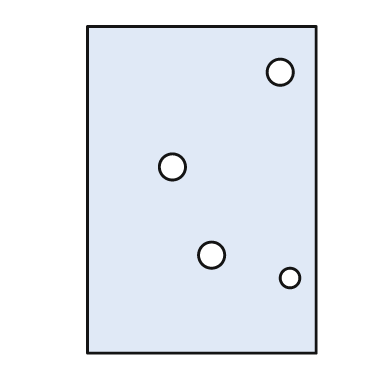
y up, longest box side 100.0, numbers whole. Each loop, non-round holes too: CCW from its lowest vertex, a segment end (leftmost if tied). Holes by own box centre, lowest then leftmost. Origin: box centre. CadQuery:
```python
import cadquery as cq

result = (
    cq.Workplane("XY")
    .moveTo(-35.0, -50.0)
    .lineTo(35.0, -50.0)
    .lineTo(35.0, 50.0)
    .lineTo(-35.0, 50.0)
    .close()
    .moveTo(27.0, -27.0)
    .circle(3.0)
    .moveTo(3.0, -20.0)
    .circle(4.0)
    .moveTo(-9.0, 7.0)
    .circle(4.0)
    .moveTo(24.0, 36.0)
    .circle(4.0)
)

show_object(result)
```